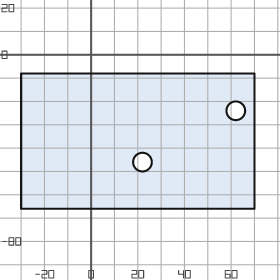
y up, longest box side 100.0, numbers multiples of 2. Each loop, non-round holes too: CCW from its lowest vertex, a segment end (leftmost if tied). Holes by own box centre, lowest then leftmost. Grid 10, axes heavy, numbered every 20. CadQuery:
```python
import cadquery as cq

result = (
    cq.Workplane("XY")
    .moveTo(-30.0, -66.0)
    .lineTo(70.0, -66.0)
    .lineTo(70.0, -8.0)
    .lineTo(-30.0, -8.0)
    .close()
    .moveTo(22.0, -46.0)
    .circle(4.0)
    .moveTo(62.0, -24.0)
    .circle(4.0)
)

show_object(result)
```